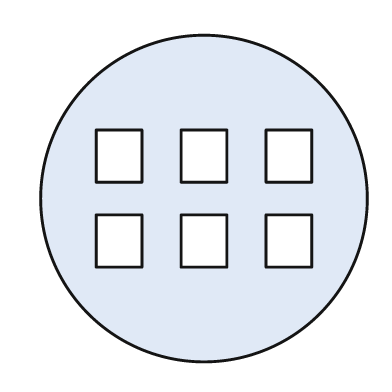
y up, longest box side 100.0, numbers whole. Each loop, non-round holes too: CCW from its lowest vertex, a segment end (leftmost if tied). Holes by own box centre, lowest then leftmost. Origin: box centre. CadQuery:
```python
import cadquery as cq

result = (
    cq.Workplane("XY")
    .moveTo(0.0, 0.0)
    .circle(50.0)
    .moveTo(-33.0, -21.0)
    .lineTo(-19.0, -21.0)
    .lineTo(-19.0, -5.0)
    .lineTo(-33.0, -5.0)
    .close()
    .moveTo(-7.0, -21.0)
    .lineTo(7.0, -21.0)
    .lineTo(7.0, -5.0)
    .lineTo(-7.0, -5.0)
    .close()
    .moveTo(19.0, -21.0)
    .lineTo(33.0, -21.0)
    .lineTo(33.0, -5.0)
    .lineTo(19.0, -5.0)
    .close()
    .moveTo(-33.0, 5.0)
    .lineTo(-19.0, 5.0)
    .lineTo(-19.0, 21.0)
    .lineTo(-33.0, 21.0)
    .close()
    .moveTo(-7.0, 5.0)
    .lineTo(7.0, 5.0)
    .lineTo(7.0, 21.0)
    .lineTo(-7.0, 21.0)
    .close()
    .moveTo(19.0, 5.0)
    .lineTo(33.0, 5.0)
    .lineTo(33.0, 21.0)
    .lineTo(19.0, 21.0)
    .close()
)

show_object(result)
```